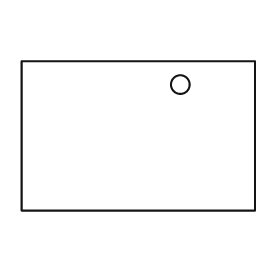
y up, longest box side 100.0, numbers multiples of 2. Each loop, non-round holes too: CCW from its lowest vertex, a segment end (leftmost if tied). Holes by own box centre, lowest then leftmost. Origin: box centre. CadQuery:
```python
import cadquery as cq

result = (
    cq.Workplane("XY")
    .moveTo(-50.0, -32.0)
    .lineTo(50.0, -32.0)
    .lineTo(50.0, 32.0)
    .lineTo(-50.0, 32.0)
    .close()
    .moveTo(18.0, 22.0)
    .circle(4.0)
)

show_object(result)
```